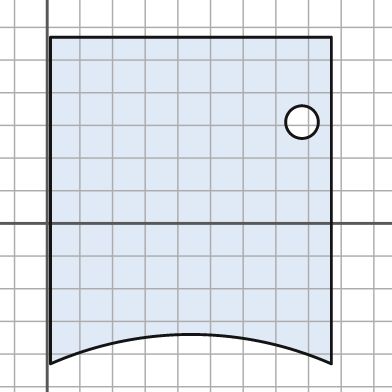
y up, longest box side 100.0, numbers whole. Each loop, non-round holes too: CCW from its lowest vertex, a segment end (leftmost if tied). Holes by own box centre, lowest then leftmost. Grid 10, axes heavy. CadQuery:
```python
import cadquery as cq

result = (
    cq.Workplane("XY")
    .moveTo(1.0, -43.0)
    .threePointArc((44.0, -34.0), (87.0, -43.0))
    .lineTo(87.0, 57.0)
    .lineTo(1.0, 57.0)
    .close()
    .moveTo(78.0, 31.0)
    .circle(5.0)
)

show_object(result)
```